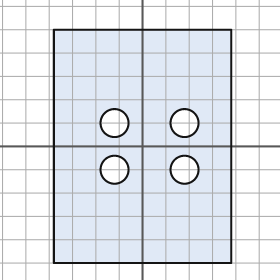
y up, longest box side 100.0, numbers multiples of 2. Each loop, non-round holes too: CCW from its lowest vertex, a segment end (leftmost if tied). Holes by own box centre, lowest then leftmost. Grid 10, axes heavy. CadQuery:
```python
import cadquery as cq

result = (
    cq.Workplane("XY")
    .moveTo(-38.0, -50.0)
    .lineTo(38.0, -50.0)
    .lineTo(38.0, 50.0)
    .lineTo(-38.0, 50.0)
    .close()
    .moveTo(-12.0, -10.0)
    .circle(6.0)
    .moveTo(18.0, -10.0)
    .circle(6.0)
    .moveTo(-12.0, 10.0)
    .circle(6.0)
    .moveTo(18.0, 10.0)
    .circle(6.0)
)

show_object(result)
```